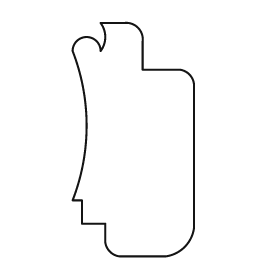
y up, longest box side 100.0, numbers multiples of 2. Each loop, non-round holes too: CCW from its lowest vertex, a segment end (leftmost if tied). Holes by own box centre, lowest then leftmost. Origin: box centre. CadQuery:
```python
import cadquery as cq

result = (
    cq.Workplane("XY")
    .moveTo(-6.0, -50.0)
    .lineTo(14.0, -50.0)
    .threePointArc((22.0, -46.0), (26.0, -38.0))
    .lineTo(26.0, 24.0)
    .threePointArc((24.0, 28.0), (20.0, 30.0))
    .lineTo(4.0, 30.0)
    .lineTo(4.0, 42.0)
    .threePointArc((2.0, 48.0), (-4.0, 50.0))
    .lineTo(-14.0, 50.0)
    .threePointArc((-12.0, 44.0), (-14.0, 38.0))
    .threePointArc((-20.0, 44.0), (-26.0, 38.0))
    .threePointArc((-20.0, 6.0), (-26.0, -26.0))
    .lineTo(-22.0, -26.0)
    .lineTo(-22.0, -36.0)
    .lineTo(-12.0, -36.0)
    .lineTo(-12.0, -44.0)
    .threePointArc((-10.0, -48.0), (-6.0, -50.0))
    .close()
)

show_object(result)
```